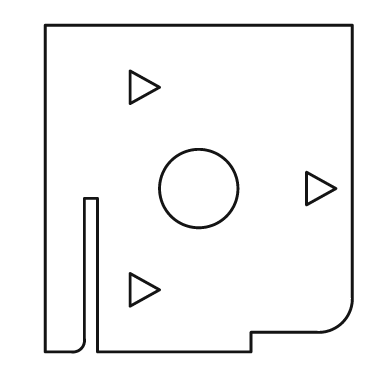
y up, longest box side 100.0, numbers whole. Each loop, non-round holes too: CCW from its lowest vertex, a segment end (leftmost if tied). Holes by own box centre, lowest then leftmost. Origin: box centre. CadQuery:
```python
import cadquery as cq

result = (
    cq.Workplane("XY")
    .moveTo(-47.0, -50.0)
    .lineTo(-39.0, -50.0)
    .threePointArc((-36.0, -49.0), (-35.0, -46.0))
    .lineTo(-35.0, -3.0)
    .lineTo(-31.0, -3.0)
    .lineTo(-31.0, -50.0)
    .lineTo(16.0, -50.0)
    .lineTo(16.0, -44.0)
    .lineTo(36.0, -44.0)
    .threePointArc((44.0, -41.0), (47.0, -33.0))
    .lineTo(47.0, 50.0)
    .lineTo(-47.0, 50.0)
    .close()
    .moveTo(-21.0, -36.0)
    .lineTo(-12.0, -31.0)
    .lineTo(-21.0, -26.0)
    .close()
    .moveTo(0.0, 0.0)
    .circle(12.0)
    .moveTo(33.0, -5.0)
    .lineTo(42.0, 0.0)
    .lineTo(33.0, 5.0)
    .close()
    .moveTo(-21.0, 26.0)
    .lineTo(-12.0, 31.0)
    .lineTo(-21.0, 36.0)
    .close()
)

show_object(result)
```